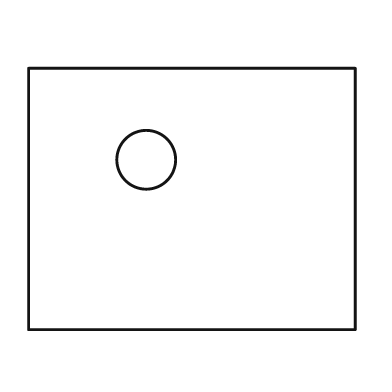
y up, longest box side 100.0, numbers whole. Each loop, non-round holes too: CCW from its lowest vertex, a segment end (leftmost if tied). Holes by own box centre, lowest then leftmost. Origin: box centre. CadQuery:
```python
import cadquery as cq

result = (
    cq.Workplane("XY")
    .moveTo(-50.0, -40.0)
    .lineTo(50.0, -40.0)
    .lineTo(50.0, 40.0)
    .lineTo(-50.0, 40.0)
    .close()
    .moveTo(-14.0, 12.0)
    .circle(9.0)
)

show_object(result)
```